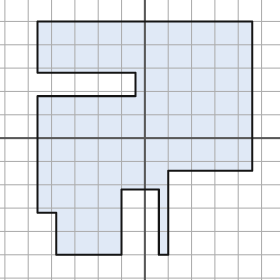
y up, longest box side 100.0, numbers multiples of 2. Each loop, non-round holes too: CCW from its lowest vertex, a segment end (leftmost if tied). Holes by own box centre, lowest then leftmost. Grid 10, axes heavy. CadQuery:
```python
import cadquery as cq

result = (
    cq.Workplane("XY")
    .moveTo(-38.0, -50.0)
    .lineTo(-10.0, -50.0)
    .lineTo(-10.0, -22.0)
    .lineTo(6.0, -22.0)
    .lineTo(6.0, -50.0)
    .lineTo(10.0, -50.0)
    .lineTo(10.0, -14.0)
    .lineTo(46.0, -14.0)
    .lineTo(46.0, 50.0)
    .lineTo(-46.0, 50.0)
    .lineTo(-46.0, 28.0)
    .lineTo(-4.0, 28.0)
    .lineTo(-4.0, 18.0)
    .lineTo(-46.0, 18.0)
    .lineTo(-46.0, -32.0)
    .lineTo(-38.0, -32.0)
    .close()
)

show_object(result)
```